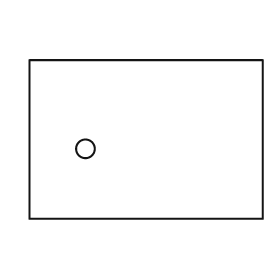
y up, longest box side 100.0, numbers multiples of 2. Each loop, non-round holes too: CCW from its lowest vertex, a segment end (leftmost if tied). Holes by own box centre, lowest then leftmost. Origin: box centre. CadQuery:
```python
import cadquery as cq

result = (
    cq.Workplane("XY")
    .moveTo(-50.0, -34.0)
    .lineTo(50.0, -34.0)
    .lineTo(50.0, 34.0)
    .lineTo(-50.0, 34.0)
    .close()
    .moveTo(-26.0, -4.0)
    .circle(4.0)
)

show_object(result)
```